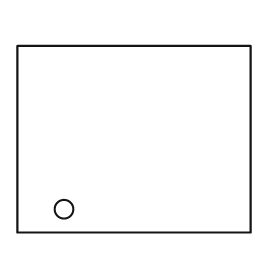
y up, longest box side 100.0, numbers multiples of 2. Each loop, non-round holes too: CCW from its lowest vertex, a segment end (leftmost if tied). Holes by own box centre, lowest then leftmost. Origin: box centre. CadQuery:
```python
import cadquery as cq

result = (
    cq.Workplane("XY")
    .moveTo(-50.0, -40.0)
    .lineTo(50.0, -40.0)
    .lineTo(50.0, 40.0)
    .lineTo(-50.0, 40.0)
    .close()
    .moveTo(-30.0, -30.0)
    .circle(4.0)
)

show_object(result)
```